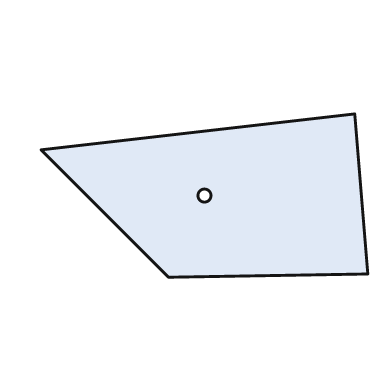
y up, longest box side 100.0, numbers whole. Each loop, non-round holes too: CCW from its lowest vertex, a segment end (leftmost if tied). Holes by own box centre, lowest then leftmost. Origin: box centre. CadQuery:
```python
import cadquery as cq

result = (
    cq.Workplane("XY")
    .moveTo(-11.0, -25.0)
    .lineTo(50.0, -24.0)
    .lineTo(46.0, 25.0)
    .lineTo(-50.0, 14.0)
    .close()
    .moveTo(0.0, 0.0)
    .circle(2.0)
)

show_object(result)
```